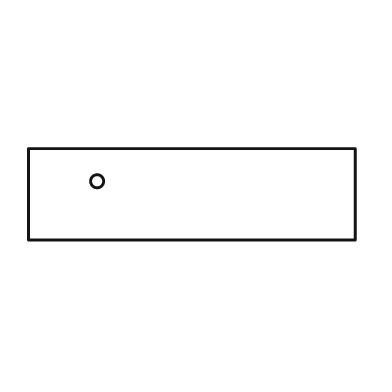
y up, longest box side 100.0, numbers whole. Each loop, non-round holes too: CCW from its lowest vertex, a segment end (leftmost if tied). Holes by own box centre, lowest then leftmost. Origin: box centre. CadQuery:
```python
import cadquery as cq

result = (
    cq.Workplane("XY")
    .moveTo(-50.0, -14.0)
    .lineTo(50.0, -14.0)
    .lineTo(50.0, 14.0)
    .lineTo(-50.0, 14.0)
    .close()
    .moveTo(-29.0, 4.0)
    .circle(2.0)
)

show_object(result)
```